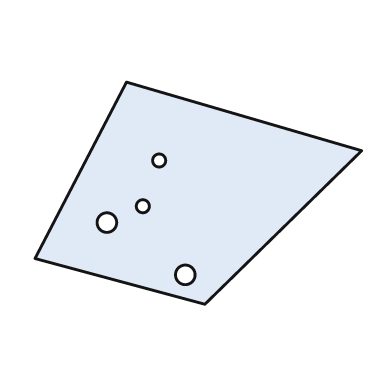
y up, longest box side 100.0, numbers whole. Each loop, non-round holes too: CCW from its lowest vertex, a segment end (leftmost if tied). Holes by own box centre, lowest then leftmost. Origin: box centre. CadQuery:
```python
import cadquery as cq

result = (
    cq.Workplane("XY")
    .moveTo(2.0, -34.0)
    .lineTo(50.0, 13.0)
    .lineTo(-22.0, 34.0)
    .lineTo(-50.0, -20.0)
    .close()
    .moveTo(-4.0, -25.0)
    .circle(3.0)
    .moveTo(-28.0, -9.0)
    .circle(3.0)
    .moveTo(-17.0, -4.0)
    .circle(2.0)
    .moveTo(-12.0, 10.0)
    .circle(2.0)
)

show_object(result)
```